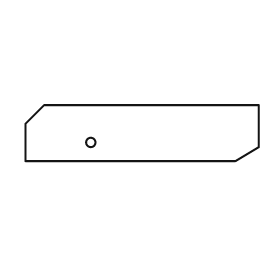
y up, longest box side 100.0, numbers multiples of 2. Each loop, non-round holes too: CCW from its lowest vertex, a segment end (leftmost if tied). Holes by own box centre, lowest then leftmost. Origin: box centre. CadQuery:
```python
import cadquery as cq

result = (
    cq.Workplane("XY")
    .moveTo(-50.0, -12.0)
    .lineTo(40.0, -12.0)
    .lineTo(50.0, -6.0)
    .lineTo(50.0, 12.0)
    .lineTo(-42.0, 12.0)
    .lineTo(-50.0, 4.0)
    .close()
    .moveTo(-22.0, -4.0)
    .circle(2.0)
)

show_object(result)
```